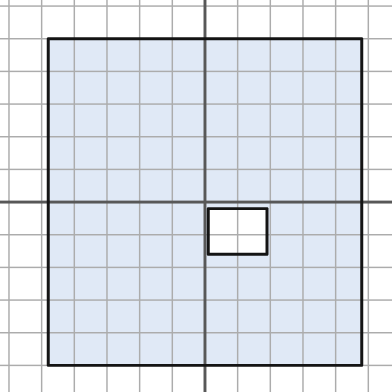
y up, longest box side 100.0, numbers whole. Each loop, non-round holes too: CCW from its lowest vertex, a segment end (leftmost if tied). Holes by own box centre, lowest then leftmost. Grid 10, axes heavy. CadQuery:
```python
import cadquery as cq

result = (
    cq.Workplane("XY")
    .moveTo(-48.0, -50.0)
    .lineTo(48.0, -50.0)
    .lineTo(48.0, 50.0)
    .lineTo(-48.0, 50.0)
    .close()
    .moveTo(1.0, -16.0)
    .lineTo(19.0, -16.0)
    .lineTo(19.0, -2.0)
    .lineTo(1.0, -2.0)
    .close()
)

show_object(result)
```